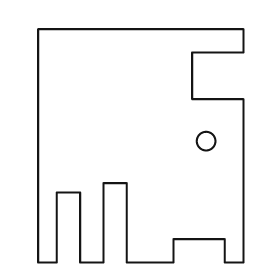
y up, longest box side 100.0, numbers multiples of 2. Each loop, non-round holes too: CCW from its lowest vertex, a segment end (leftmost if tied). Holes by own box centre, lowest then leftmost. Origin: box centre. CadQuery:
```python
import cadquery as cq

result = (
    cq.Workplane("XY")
    .moveTo(-44.0, -50.0)
    .lineTo(-36.0, -50.0)
    .lineTo(-36.0, -20.0)
    .lineTo(-26.0, -20.0)
    .lineTo(-26.0, -50.0)
    .lineTo(-16.0, -50.0)
    .lineTo(-16.0, -16.0)
    .lineTo(-6.0, -16.0)
    .lineTo(-6.0, -50.0)
    .lineTo(14.0, -50.0)
    .lineTo(14.0, -40.0)
    .lineTo(36.0, -40.0)
    .lineTo(36.0, -50.0)
    .lineTo(44.0, -50.0)
    .lineTo(44.0, 20.0)
    .lineTo(22.0, 20.0)
    .lineTo(22.0, 40.0)
    .lineTo(44.0, 40.0)
    .lineTo(44.0, 50.0)
    .lineTo(-44.0, 50.0)
    .close()
    .moveTo(28.0, 2.0)
    .circle(4.0)
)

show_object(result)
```